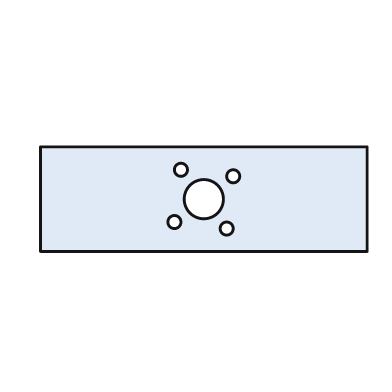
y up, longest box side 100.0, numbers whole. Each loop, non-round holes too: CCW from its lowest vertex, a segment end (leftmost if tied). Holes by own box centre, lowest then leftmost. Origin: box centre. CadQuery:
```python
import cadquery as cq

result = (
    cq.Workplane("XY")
    .moveTo(-50.0, -16.0)
    .lineTo(50.0, -16.0)
    .lineTo(50.0, 16.0)
    .lineTo(-50.0, 16.0)
    .close()
    .moveTo(7.0, -9.0)
    .circle(2.0)
    .moveTo(-9.0, -7.0)
    .circle(2.0)
    .moveTo(0.0, 0.0)
    .circle(6.0)
    .moveTo(9.0, 7.0)
    .circle(2.0)
    .moveTo(-7.0, 9.0)
    .circle(2.0)
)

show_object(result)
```